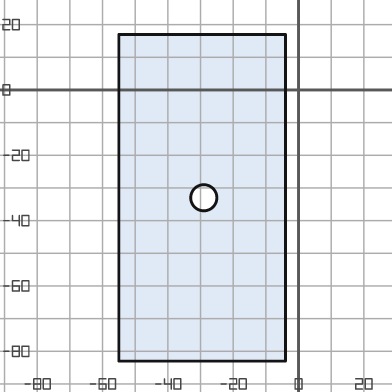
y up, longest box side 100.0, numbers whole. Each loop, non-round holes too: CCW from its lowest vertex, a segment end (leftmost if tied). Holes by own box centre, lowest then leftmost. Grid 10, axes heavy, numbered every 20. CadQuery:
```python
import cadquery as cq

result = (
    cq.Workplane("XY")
    .moveTo(-55.0, -83.0)
    .lineTo(-4.0, -83.0)
    .lineTo(-4.0, 17.0)
    .lineTo(-55.0, 17.0)
    .close()
    .moveTo(-29.0, -33.0)
    .circle(4.0)
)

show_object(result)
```